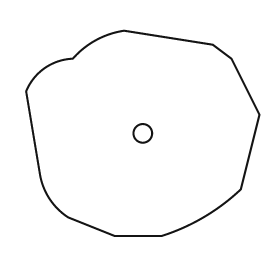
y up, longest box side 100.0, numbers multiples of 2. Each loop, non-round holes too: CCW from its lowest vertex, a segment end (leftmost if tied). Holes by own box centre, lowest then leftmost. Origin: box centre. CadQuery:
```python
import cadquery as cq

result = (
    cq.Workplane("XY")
    .moveTo(-12.0, -44.0)
    .lineTo(8.0, -44.0)
    .threePointArc((26.0, -36.0), (42.0, -24.0))
    .lineTo(50.0, 8.0)
    .lineTo(38.0, 32.0)
    .lineTo(30.0, 38.0)
    .lineTo(-8.0, 44.0)
    .threePointArc((-20.0, 40.0), (-30.0, 32.0))
    .threePointArc((-42.0, 28.0), (-50.0, 18.0))
    .lineTo(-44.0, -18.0)
    .threePointArc((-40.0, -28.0), (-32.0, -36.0))
    .close()
    .moveTo(0.0, 0.0)
    .circle(4.0)
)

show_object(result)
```